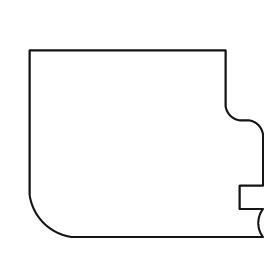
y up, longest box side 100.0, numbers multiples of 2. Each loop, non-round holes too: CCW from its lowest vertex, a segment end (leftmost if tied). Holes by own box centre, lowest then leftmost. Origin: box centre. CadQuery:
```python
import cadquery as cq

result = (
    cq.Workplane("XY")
    .moveTo(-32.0, -40.0)
    .lineTo(50.0, -40.0)
    .threePointArc((48.0, -34.0), (50.0, -28.0))
    .lineTo(40.0, -28.0)
    .lineTo(40.0, -18.0)
    .lineTo(50.0, -18.0)
    .lineTo(50.0, 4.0)
    .threePointArc((48.0, 8.0), (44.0, 10.0))
    .lineTo(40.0, 10.0)
    .threePointArc((36.0, 12.0), (34.0, 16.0))
    .lineTo(34.0, 40.0)
    .lineTo(-50.0, 40.0)
    .lineTo(-50.0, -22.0)
    .threePointArc((-44.0, -34.0), (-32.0, -40.0))
    .close()
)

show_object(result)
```